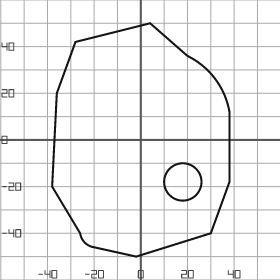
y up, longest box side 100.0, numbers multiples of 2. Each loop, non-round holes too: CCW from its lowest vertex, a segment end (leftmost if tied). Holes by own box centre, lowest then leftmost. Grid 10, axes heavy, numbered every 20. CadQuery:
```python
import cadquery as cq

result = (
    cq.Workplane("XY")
    .moveTo(-2.0, -50.0)
    .lineTo(30.0, -40.0)
    .lineTo(38.0, -18.0)
    .lineTo(38.0, 12.0)
    .threePointArc((32.0, 26.0), (20.0, 36.0))
    .lineTo(4.0, 50.0)
    .lineTo(-28.0, 42.0)
    .lineTo(-36.0, 20.0)
    .lineTo(-38.0, -20.0)
    .lineTo(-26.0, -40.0)
    .threePointArc((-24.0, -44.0), (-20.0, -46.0))
    .close()
    .moveTo(18.0, -18.0)
    .circle(8.0)
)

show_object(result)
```